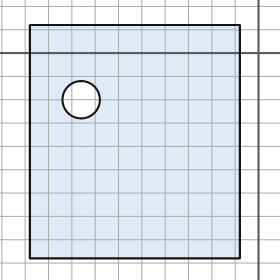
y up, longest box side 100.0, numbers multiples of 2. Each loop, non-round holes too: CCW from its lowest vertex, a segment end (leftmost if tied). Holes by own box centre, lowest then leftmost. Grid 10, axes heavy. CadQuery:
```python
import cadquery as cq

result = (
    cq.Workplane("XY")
    .moveTo(-98.0, -88.0)
    .lineTo(-8.0, -88.0)
    .lineTo(-8.0, 12.0)
    .lineTo(-98.0, 12.0)
    .close()
    .moveTo(-76.0, -20.0)
    .circle(8.0)
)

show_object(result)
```